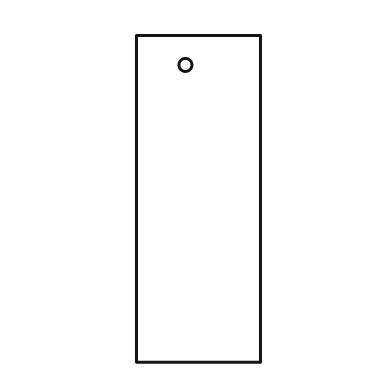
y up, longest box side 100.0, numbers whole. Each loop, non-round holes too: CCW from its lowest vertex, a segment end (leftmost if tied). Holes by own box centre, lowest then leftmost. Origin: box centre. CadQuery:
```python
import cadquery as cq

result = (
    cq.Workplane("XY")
    .moveTo(-19.0, -50.0)
    .lineTo(19.0, -50.0)
    .lineTo(19.0, 50.0)
    .lineTo(-19.0, 50.0)
    .close()
    .moveTo(-4.0, 41.0)
    .circle(2.0)
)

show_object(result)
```